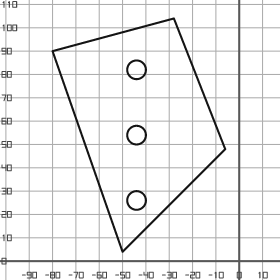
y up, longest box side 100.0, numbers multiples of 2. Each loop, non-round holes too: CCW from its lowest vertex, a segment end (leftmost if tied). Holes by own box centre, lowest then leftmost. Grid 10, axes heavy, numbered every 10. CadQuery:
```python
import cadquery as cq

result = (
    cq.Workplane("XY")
    .moveTo(-50.0, 4.0)
    .lineTo(-6.0, 48.0)
    .lineTo(-28.0, 104.0)
    .lineTo(-80.0, 90.0)
    .close()
    .moveTo(-44.0, 26.0)
    .circle(4.0)
    .moveTo(-44.0, 54.0)
    .circle(4.0)
    .moveTo(-44.0, 82.0)
    .circle(4.0)
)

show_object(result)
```